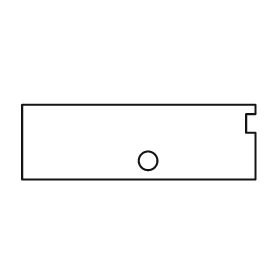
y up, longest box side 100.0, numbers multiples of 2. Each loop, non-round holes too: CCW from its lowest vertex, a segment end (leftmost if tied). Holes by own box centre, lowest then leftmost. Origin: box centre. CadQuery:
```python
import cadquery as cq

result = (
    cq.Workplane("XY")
    .moveTo(-50.0, -16.0)
    .lineTo(50.0, -16.0)
    .lineTo(50.0, 4.0)
    .lineTo(46.0, 4.0)
    .lineTo(46.0, 12.0)
    .lineTo(50.0, 12.0)
    .lineTo(50.0, 16.0)
    .lineTo(-50.0, 16.0)
    .close()
    .moveTo(4.0, -8.0)
    .circle(4.0)
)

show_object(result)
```